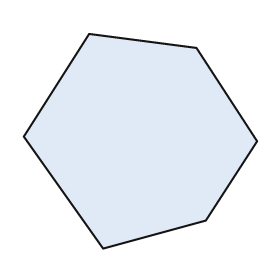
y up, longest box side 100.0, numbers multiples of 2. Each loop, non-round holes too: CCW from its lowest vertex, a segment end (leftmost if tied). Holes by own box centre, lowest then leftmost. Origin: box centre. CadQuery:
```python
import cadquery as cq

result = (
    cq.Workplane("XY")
    .moveTo(-16.0, -46.0)
    .lineTo(28.0, -34.0)
    .lineTo(50.0, 0.0)
    .lineTo(24.0, 40.0)
    .lineTo(-22.0, 46.0)
    .lineTo(-50.0, 2.0)
    .close()
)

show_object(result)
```